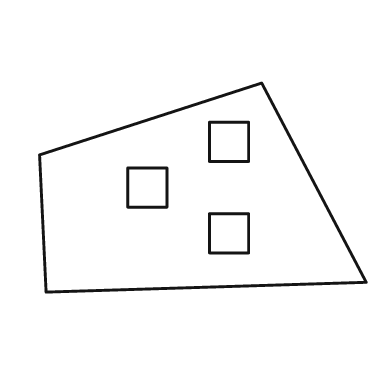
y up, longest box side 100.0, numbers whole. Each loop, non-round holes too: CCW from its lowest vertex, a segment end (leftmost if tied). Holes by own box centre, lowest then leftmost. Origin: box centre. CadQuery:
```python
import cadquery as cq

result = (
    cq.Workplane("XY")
    .moveTo(-48.0, -32.0)
    .lineTo(50.0, -29.0)
    .lineTo(18.0, 32.0)
    .lineTo(-50.0, 10.0)
    .close()
    .moveTo(2.0, -20.0)
    .lineTo(14.0, -20.0)
    .lineTo(14.0, -8.0)
    .lineTo(2.0, -8.0)
    .close()
    .moveTo(-23.0, -6.0)
    .lineTo(-11.0, -6.0)
    .lineTo(-11.0, 6.0)
    .lineTo(-23.0, 6.0)
    .close()
    .moveTo(2.0, 8.0)
    .lineTo(14.0, 8.0)
    .lineTo(14.0, 20.0)
    .lineTo(2.0, 20.0)
    .close()
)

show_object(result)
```